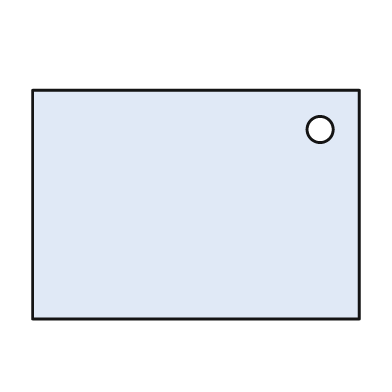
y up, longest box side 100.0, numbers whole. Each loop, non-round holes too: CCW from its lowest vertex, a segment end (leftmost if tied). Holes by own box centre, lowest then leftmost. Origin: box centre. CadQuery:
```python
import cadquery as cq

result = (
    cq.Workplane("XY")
    .moveTo(-50.0, -35.0)
    .lineTo(50.0, -35.0)
    .lineTo(50.0, 35.0)
    .lineTo(-50.0, 35.0)
    .close()
    .moveTo(38.0, 23.0)
    .circle(4.0)
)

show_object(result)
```